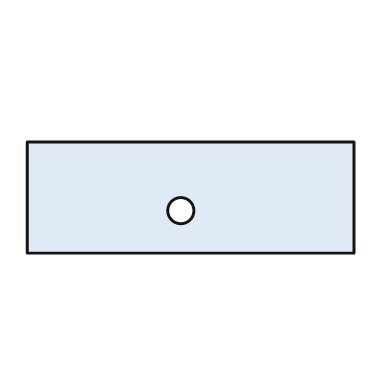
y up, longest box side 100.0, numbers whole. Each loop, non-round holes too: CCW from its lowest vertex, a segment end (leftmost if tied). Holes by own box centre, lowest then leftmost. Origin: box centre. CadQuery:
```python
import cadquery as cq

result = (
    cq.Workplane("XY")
    .moveTo(-50.0, -17.0)
    .lineTo(50.0, -17.0)
    .lineTo(50.0, 17.0)
    .lineTo(-50.0, 17.0)
    .close()
    .moveTo(-3.0, -4.0)
    .circle(4.0)
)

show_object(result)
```